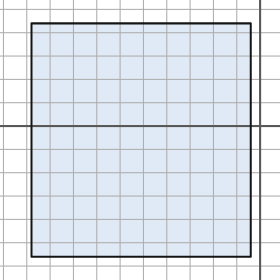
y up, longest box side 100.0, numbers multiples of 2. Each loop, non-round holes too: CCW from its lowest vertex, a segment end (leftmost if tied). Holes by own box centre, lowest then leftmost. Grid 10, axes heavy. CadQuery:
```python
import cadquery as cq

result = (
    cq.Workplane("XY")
    .moveTo(-98.0, -56.0)
    .lineTo(-4.0, -56.0)
    .lineTo(-4.0, 44.0)
    .lineTo(-98.0, 44.0)
    .close()
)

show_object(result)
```